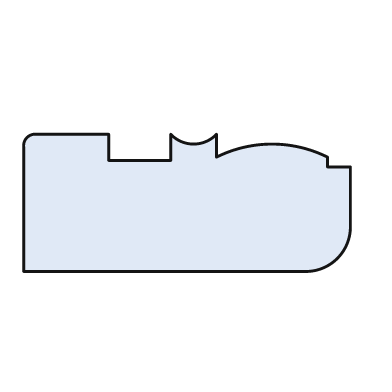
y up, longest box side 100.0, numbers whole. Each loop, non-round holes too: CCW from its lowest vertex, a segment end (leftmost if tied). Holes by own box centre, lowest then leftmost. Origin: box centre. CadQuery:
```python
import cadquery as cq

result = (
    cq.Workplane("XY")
    .moveTo(-50.0, -21.0)
    .lineTo(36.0, -21.0)
    .threePointArc((46.0, -17.0), (50.0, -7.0))
    .lineTo(50.0, 11.0)
    .lineTo(43.0, 11.0)
    .lineTo(43.0, 14.0)
    .threePointArc((26.0, 18.0), (9.0, 14.0))
    .lineTo(9.0, 21.0)
    .threePointArc((2.0, 18.0), (-5.0, 21.0))
    .lineTo(-5.0, 13.0)
    .lineTo(-24.0, 13.0)
    .lineTo(-24.0, 21.0)
    .lineTo(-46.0, 21.0)
    .threePointArc((-49.0, 20.0), (-50.0, 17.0))
    .close()
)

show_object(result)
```